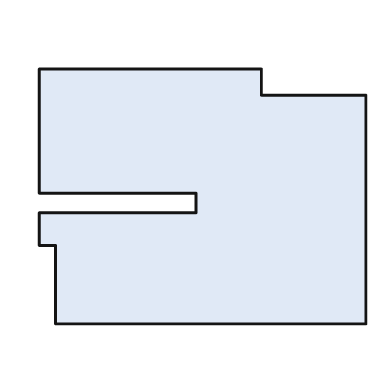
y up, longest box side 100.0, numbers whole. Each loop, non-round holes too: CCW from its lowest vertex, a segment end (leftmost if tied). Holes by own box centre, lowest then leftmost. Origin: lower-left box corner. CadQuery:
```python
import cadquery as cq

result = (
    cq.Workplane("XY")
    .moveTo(5.0, 0.0)
    .lineTo(100.0, 0.0)
    .lineTo(100.0, 70.0)
    .lineTo(68.0, 70.0)
    .lineTo(68.0, 78.0)
    .lineTo(0.0, 78.0)
    .lineTo(0.0, 40.0)
    .lineTo(48.0, 40.0)
    .lineTo(48.0, 34.0)
    .lineTo(0.0, 34.0)
    .lineTo(0.0, 24.0)
    .lineTo(5.0, 24.0)
    .close()
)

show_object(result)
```